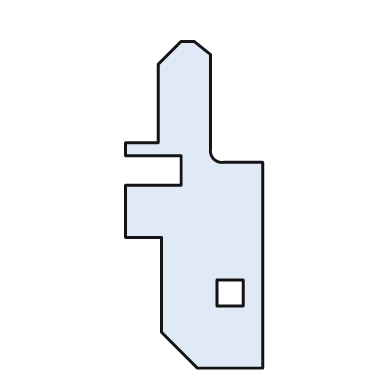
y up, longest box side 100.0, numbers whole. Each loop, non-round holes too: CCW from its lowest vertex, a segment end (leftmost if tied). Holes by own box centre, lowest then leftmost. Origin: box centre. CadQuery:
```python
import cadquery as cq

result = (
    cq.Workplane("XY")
    .moveTo(1.0, -50.0)
    .lineTo(21.0, -50.0)
    .lineTo(21.0, 13.0)
    .lineTo(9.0, 13.0)
    .threePointArc((6.0, 14.0), (5.0, 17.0))
    .lineTo(5.0, 46.0)
    .lineTo(0.0, 50.0)
    .lineTo(-4.0, 50.0)
    .lineTo(-11.0, 43.0)
    .lineTo(-11.0, 19.0)
    .lineTo(-21.0, 19.0)
    .lineTo(-21.0, 15.0)
    .lineTo(-4.0, 15.0)
    .lineTo(-4.0, 6.0)
    .lineTo(-21.0, 6.0)
    .lineTo(-21.0, -10.0)
    .lineTo(-10.0, -10.0)
    .lineTo(-10.0, -39.0)
    .close()
    .moveTo(7.0, -31.0)
    .lineTo(15.0, -31.0)
    .lineTo(15.0, -23.0)
    .lineTo(7.0, -23.0)
    .close()
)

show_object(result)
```